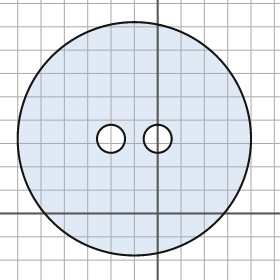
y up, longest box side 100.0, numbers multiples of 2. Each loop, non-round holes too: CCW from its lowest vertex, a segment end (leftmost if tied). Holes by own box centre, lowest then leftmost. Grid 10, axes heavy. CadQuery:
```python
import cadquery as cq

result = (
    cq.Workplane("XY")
    .moveTo(-10.0, 32.0)
    .circle(50.0)
    .moveTo(-20.0, 32.0)
    .circle(6.0)
    .moveTo(0.0, 32.0)
    .circle(6.0)
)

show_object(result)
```